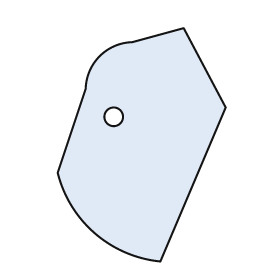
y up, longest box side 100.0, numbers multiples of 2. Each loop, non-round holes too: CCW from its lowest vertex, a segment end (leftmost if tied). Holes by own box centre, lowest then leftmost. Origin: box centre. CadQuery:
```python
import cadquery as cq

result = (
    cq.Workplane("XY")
    .moveTo(8.0, -50.0)
    .lineTo(36.0, 16.0)
    .lineTo(18.0, 50.0)
    .lineTo(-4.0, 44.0)
    .threePointArc((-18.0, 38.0), (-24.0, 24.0))
    .lineTo(-36.0, -12.0)
    .threePointArc((-20.0, -38.0), (8.0, -50.0))
    .close()
    .moveTo(-12.0, 12.0)
    .circle(4.0)
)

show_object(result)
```